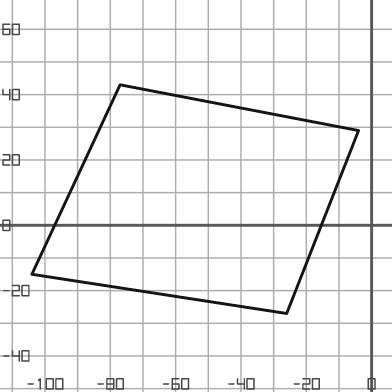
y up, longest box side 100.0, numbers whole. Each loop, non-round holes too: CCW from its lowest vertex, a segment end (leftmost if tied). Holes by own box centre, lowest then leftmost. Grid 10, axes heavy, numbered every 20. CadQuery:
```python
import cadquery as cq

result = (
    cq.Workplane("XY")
    .moveTo(-26.0, -27.0)
    .lineTo(-4.0, 29.0)
    .lineTo(-77.0, 43.0)
    .lineTo(-104.0, -15.0)
    .close()
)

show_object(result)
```